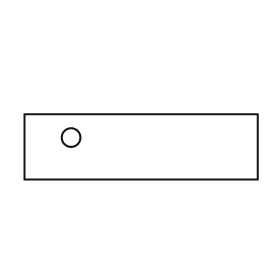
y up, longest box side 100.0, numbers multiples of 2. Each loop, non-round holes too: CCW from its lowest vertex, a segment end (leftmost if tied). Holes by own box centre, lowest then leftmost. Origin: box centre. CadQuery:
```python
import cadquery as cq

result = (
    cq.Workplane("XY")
    .moveTo(-50.0, -14.0)
    .lineTo(50.0, -14.0)
    .lineTo(50.0, 14.0)
    .lineTo(-50.0, 14.0)
    .close()
    .moveTo(-30.0, 4.0)
    .circle(4.0)
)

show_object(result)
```